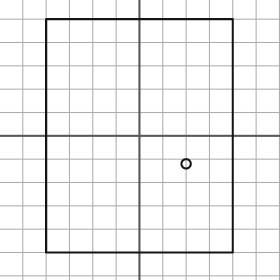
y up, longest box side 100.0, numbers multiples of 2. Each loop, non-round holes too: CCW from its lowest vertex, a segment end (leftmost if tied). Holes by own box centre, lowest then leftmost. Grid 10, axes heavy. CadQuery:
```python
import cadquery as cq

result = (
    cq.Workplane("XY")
    .moveTo(-40.0, -50.0)
    .lineTo(40.0, -50.0)
    .lineTo(40.0, 50.0)
    .lineTo(-40.0, 50.0)
    .close()
    .moveTo(20.0, -12.0)
    .circle(2.0)
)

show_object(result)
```